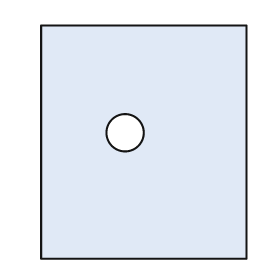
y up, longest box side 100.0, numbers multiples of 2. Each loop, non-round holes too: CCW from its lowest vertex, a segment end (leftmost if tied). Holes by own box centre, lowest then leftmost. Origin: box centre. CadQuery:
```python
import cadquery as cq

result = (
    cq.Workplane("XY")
    .moveTo(-44.0, -50.0)
    .lineTo(44.0, -50.0)
    .lineTo(44.0, 50.0)
    .lineTo(-44.0, 50.0)
    .close()
    .moveTo(-8.0, 4.0)
    .circle(8.0)
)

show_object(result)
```